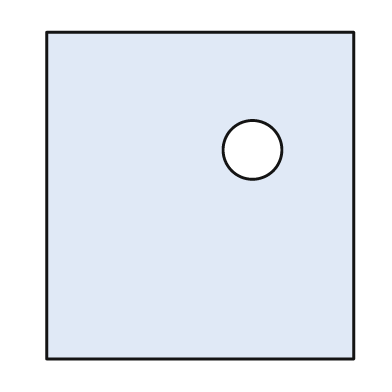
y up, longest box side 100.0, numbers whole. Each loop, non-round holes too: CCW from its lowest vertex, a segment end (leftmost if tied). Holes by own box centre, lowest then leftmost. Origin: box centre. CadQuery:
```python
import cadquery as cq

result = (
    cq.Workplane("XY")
    .moveTo(-47.0, -50.0)
    .lineTo(47.0, -50.0)
    .lineTo(47.0, 50.0)
    .lineTo(-47.0, 50.0)
    .close()
    .moveTo(16.0, 14.0)
    .circle(9.0)
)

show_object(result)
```